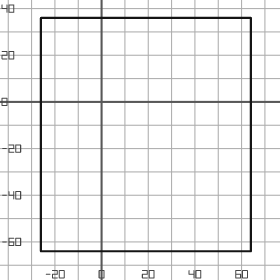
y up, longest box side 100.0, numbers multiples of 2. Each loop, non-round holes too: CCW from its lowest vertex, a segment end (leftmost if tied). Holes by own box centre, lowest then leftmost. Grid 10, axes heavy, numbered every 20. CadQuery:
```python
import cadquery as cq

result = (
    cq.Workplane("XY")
    .moveTo(-26.0, -64.0)
    .lineTo(64.0, -64.0)
    .lineTo(64.0, 36.0)
    .lineTo(-26.0, 36.0)
    .close()
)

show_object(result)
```